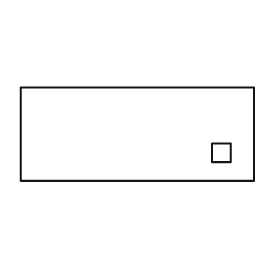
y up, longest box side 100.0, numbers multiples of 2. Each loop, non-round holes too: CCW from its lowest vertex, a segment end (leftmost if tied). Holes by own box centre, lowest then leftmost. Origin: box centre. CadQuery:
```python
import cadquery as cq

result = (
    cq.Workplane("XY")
    .moveTo(-50.0, -20.0)
    .lineTo(50.0, -20.0)
    .lineTo(50.0, 20.0)
    .lineTo(-50.0, 20.0)
    .close()
    .moveTo(32.0, -12.0)
    .lineTo(40.0, -12.0)
    .lineTo(40.0, -4.0)
    .lineTo(32.0, -4.0)
    .close()
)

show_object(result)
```